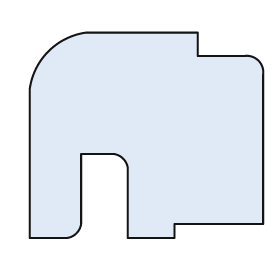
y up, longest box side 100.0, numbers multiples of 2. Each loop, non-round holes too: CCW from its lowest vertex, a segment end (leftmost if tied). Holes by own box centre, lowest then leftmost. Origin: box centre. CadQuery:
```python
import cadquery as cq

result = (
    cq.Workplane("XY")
    .moveTo(-50.0, -44.0)
    .lineTo(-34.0, -44.0)
    .threePointArc((-30.0, -42.0), (-28.0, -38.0))
    .lineTo(-28.0, -8.0)
    .lineTo(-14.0, -8.0)
    .threePointArc((-10.0, -10.0), (-8.0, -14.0))
    .lineTo(-8.0, -44.0)
    .lineTo(12.0, -44.0)
    .lineTo(12.0, -38.0)
    .lineTo(50.0, -38.0)
    .lineTo(50.0, 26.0)
    .threePointArc((48.0, 32.0), (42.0, 34.0))
    .lineTo(22.0, 34.0)
    .lineTo(22.0, 44.0)
    .lineTo(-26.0, 44.0)
    .threePointArc((-42.0, 36.0), (-50.0, 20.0))
    .close()
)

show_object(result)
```